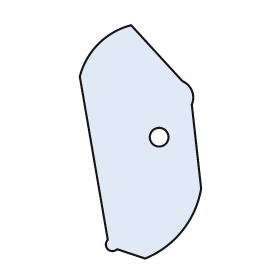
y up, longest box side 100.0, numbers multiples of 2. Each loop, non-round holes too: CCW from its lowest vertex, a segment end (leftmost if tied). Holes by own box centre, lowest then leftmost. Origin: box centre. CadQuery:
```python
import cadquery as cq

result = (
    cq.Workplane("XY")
    .moveTo(2.0, -50.0)
    .threePointArc((18.0, -38.0), (26.0, -20.0))
    .lineTo(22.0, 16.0)
    .threePointArc((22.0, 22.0), (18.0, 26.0))
    .lineTo(-4.0, 50.0)
    .threePointArc((-18.0, 42.0), (-26.0, 28.0))
    .lineTo(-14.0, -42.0)
    .threePointArc((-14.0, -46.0), (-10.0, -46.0))
    .close()
    .moveTo(8.0, 2.0)
    .circle(4.0)
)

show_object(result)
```